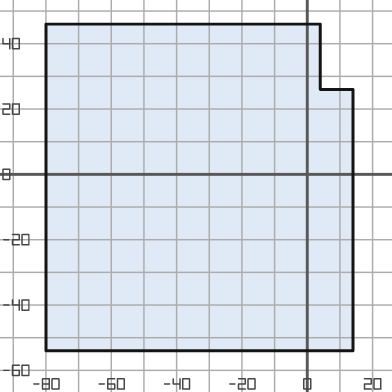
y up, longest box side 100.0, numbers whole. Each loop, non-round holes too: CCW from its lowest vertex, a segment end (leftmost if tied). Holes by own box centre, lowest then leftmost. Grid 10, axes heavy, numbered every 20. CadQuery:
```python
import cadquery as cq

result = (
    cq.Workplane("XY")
    .moveTo(-80.0, -54.0)
    .lineTo(14.0, -54.0)
    .lineTo(14.0, 26.0)
    .lineTo(4.0, 26.0)
    .lineTo(4.0, 46.0)
    .lineTo(-80.0, 46.0)
    .close()
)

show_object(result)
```